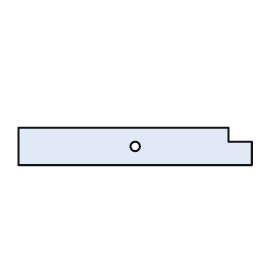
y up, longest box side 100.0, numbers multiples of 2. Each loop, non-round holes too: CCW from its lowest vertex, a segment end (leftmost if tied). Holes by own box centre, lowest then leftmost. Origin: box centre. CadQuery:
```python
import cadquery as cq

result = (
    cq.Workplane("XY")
    .moveTo(-50.0, -8.0)
    .lineTo(50.0, -8.0)
    .lineTo(50.0, 2.0)
    .lineTo(40.0, 2.0)
    .lineTo(40.0, 8.0)
    .lineTo(-50.0, 8.0)
    .close()
    .moveTo(0.0, 0.0)
    .circle(2.0)
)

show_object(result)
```